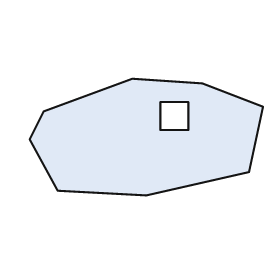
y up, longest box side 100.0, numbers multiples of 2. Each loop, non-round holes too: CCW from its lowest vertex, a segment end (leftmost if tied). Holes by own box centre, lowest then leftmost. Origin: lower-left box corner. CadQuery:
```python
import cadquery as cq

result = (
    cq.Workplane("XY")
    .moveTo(50.0, 0.0)
    .lineTo(94.0, 10.0)
    .lineTo(100.0, 38.0)
    .lineTo(74.0, 48.0)
    .lineTo(44.0, 50.0)
    .lineTo(6.0, 36.0)
    .lineTo(0.0, 24.0)
    .lineTo(12.0, 2.0)
    .close()
    .moveTo(56.0, 28.0)
    .lineTo(68.0, 28.0)
    .lineTo(68.0, 40.0)
    .lineTo(56.0, 40.0)
    .close()
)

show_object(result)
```